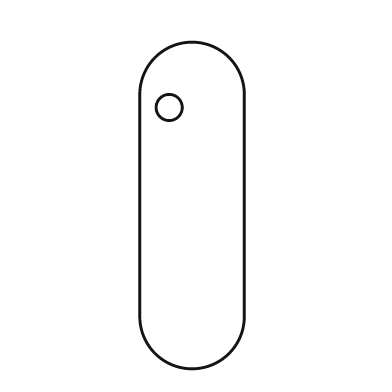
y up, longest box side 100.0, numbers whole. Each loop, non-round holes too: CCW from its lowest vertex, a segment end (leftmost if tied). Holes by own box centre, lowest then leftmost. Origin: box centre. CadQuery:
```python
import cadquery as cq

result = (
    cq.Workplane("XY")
    .moveTo(-16.0, -34.0)
    .threePointArc((0.0, -50.0), (16.0, -34.0))
    .lineTo(16.0, 34.0)
    .threePointArc((0.0, 50.0), (-16.0, 34.0))
    .close()
    .moveTo(-7.0, 30.0)
    .circle(4.0)
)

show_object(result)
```